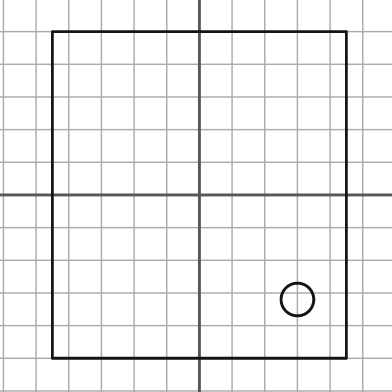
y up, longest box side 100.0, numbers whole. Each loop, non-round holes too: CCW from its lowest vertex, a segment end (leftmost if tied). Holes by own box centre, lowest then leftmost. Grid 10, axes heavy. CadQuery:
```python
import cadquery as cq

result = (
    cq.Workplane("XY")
    .moveTo(-45.0, -50.0)
    .lineTo(45.0, -50.0)
    .lineTo(45.0, 50.0)
    .lineTo(-45.0, 50.0)
    .close()
    .moveTo(30.0, -32.0)
    .circle(5.0)
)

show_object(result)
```